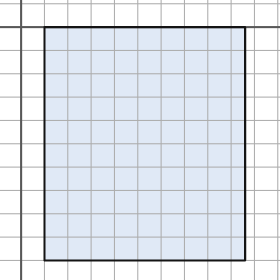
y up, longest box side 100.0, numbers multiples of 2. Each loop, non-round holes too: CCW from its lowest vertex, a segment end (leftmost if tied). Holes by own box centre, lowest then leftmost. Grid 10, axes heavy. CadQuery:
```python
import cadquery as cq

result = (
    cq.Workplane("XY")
    .moveTo(10.0, -100.0)
    .lineTo(96.0, -100.0)
    .lineTo(96.0, 0.0)
    .lineTo(10.0, 0.0)
    .close()
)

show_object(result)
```